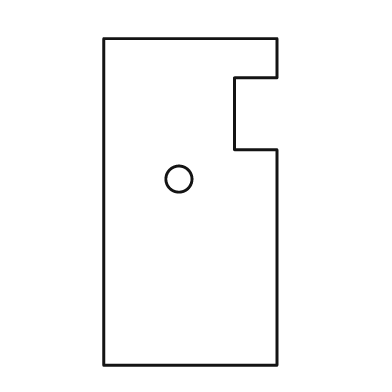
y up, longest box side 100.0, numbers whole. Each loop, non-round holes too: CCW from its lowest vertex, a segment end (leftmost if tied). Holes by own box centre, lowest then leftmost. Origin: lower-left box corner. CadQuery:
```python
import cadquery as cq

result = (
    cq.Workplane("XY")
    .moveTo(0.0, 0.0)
    .lineTo(53.0, 0.0)
    .lineTo(53.0, 66.0)
    .lineTo(40.0, 66.0)
    .lineTo(40.0, 88.0)
    .lineTo(53.0, 88.0)
    .lineTo(53.0, 100.0)
    .lineTo(0.0, 100.0)
    .close()
    .moveTo(23.0, 57.0)
    .circle(4.0)
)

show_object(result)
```